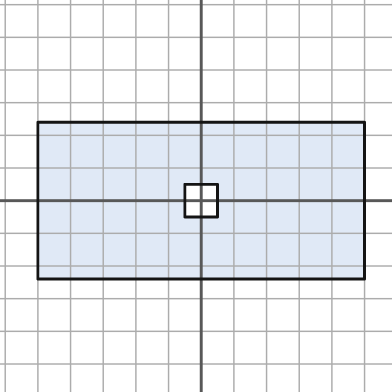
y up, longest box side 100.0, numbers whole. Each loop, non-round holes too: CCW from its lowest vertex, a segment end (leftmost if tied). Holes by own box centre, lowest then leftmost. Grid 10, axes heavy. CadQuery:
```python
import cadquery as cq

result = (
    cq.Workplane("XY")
    .moveTo(-50.0, -24.0)
    .lineTo(50.0, -24.0)
    .lineTo(50.0, 24.0)
    .lineTo(-50.0, 24.0)
    .close()
    .moveTo(-5.0, -5.0)
    .lineTo(5.0, -5.0)
    .lineTo(5.0, 5.0)
    .lineTo(-5.0, 5.0)
    .close()
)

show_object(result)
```